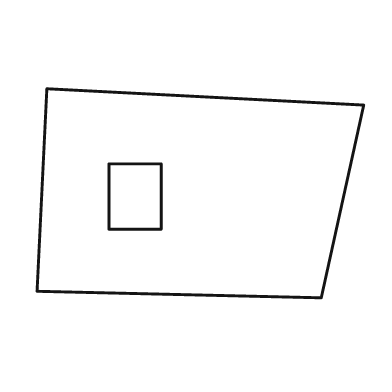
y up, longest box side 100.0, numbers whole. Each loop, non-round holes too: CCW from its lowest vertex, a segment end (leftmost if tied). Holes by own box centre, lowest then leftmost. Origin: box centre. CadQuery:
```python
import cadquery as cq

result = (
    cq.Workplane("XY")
    .moveTo(37.0, -32.0)
    .lineTo(50.0, 27.0)
    .lineTo(-47.0, 32.0)
    .lineTo(-50.0, -30.0)
    .close()
    .moveTo(-28.0, -11.0)
    .lineTo(-12.0, -11.0)
    .lineTo(-12.0, 9.0)
    .lineTo(-28.0, 9.0)
    .close()
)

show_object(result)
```